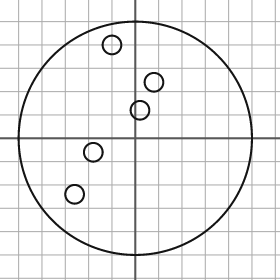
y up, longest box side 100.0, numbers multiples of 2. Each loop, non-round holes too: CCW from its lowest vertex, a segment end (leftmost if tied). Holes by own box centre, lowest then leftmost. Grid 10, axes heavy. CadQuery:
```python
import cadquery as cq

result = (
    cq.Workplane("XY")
    .moveTo(0.0, 0.0)
    .circle(50.0)
    .moveTo(-26.0, -24.0)
    .circle(4.0)
    .moveTo(-18.0, -6.0)
    .circle(4.0)
    .moveTo(2.0, 12.0)
    .circle(4.0)
    .moveTo(8.0, 24.0)
    .circle(4.0)
    .moveTo(-10.0, 40.0)
    .circle(4.0)
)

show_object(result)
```